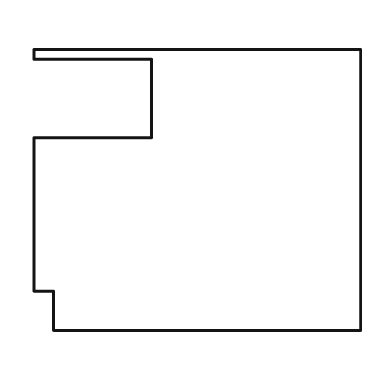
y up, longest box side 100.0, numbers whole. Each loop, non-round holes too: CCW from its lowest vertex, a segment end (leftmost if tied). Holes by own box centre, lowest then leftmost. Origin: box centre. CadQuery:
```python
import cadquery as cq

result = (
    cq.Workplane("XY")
    .moveTo(-44.0, -43.0)
    .lineTo(50.0, -43.0)
    .lineTo(50.0, 43.0)
    .lineTo(-50.0, 43.0)
    .lineTo(-50.0, 40.0)
    .lineTo(-14.0, 40.0)
    .lineTo(-14.0, 16.0)
    .lineTo(-50.0, 16.0)
    .lineTo(-50.0, -31.0)
    .lineTo(-44.0, -31.0)
    .close()
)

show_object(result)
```